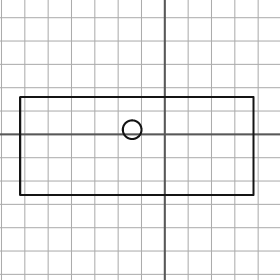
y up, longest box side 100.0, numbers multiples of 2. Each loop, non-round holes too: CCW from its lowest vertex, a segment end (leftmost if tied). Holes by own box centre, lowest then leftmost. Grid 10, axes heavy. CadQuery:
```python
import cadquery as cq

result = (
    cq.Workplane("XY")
    .moveTo(-62.0, -26.0)
    .lineTo(38.0, -26.0)
    .lineTo(38.0, 16.0)
    .lineTo(-62.0, 16.0)
    .close()
    .moveTo(-14.0, 2.0)
    .circle(4.0)
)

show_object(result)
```